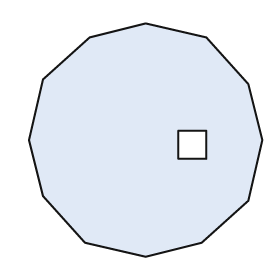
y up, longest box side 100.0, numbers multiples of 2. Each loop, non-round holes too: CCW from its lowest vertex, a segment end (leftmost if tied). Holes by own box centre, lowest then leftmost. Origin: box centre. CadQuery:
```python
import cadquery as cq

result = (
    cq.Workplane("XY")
    .moveTo(0.0, -50.0)
    .lineTo(24.0, -44.0)
    .lineTo(44.0, -26.0)
    .lineTo(50.0, 0.0)
    .lineTo(44.0, 24.0)
    .lineTo(26.0, 44.0)
    .lineTo(0.0, 50.0)
    .lineTo(-24.0, 44.0)
    .lineTo(-44.0, 26.0)
    .lineTo(-50.0, 0.0)
    .lineTo(-44.0, -24.0)
    .lineTo(-26.0, -44.0)
    .close()
    .moveTo(14.0, -8.0)
    .lineTo(26.0, -8.0)
    .lineTo(26.0, 4.0)
    .lineTo(14.0, 4.0)
    .close()
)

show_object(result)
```